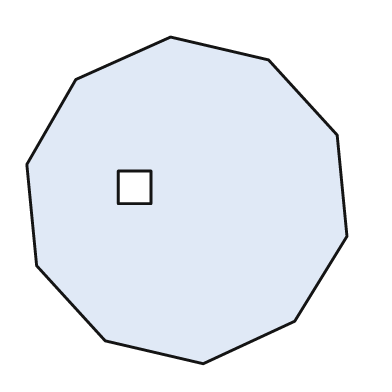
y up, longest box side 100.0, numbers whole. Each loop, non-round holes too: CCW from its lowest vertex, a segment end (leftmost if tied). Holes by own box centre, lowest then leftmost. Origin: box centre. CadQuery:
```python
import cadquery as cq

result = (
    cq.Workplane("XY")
    .moveTo(5.0, -50.0)
    .lineTo(33.0, -37.0)
    .lineTo(49.0, -11.0)
    .lineTo(46.0, 20.0)
    .lineTo(25.0, 43.0)
    .lineTo(-5.0, 50.0)
    .lineTo(-34.0, 37.0)
    .lineTo(-49.0, 11.0)
    .lineTo(-46.0, -20.0)
    .lineTo(-25.0, -43.0)
    .close()
    .moveTo(-21.0, -1.0)
    .lineTo(-11.0, -1.0)
    .lineTo(-11.0, 9.0)
    .lineTo(-21.0, 9.0)
    .close()
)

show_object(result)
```